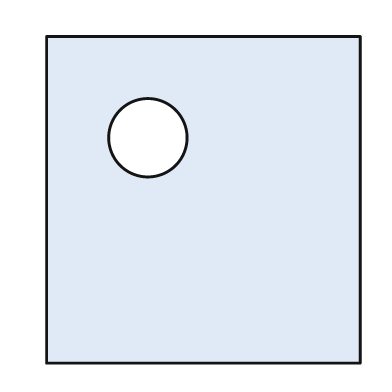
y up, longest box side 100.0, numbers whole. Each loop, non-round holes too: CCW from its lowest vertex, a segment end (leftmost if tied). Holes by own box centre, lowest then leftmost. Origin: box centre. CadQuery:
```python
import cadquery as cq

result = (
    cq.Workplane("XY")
    .moveTo(-48.0, -50.0)
    .lineTo(48.0, -50.0)
    .lineTo(48.0, 50.0)
    .lineTo(-48.0, 50.0)
    .close()
    .moveTo(-17.0, 19.0)
    .circle(12.0)
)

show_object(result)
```